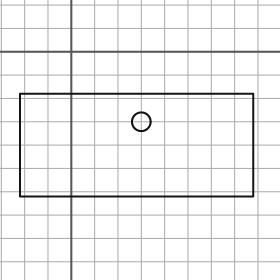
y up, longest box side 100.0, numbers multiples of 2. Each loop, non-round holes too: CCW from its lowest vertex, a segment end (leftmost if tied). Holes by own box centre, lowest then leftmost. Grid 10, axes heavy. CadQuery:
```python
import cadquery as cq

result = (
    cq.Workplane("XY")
    .moveTo(-22.0, -62.0)
    .lineTo(78.0, -62.0)
    .lineTo(78.0, -18.0)
    .lineTo(-22.0, -18.0)
    .close()
    .moveTo(30.0, -30.0)
    .circle(4.0)
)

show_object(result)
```